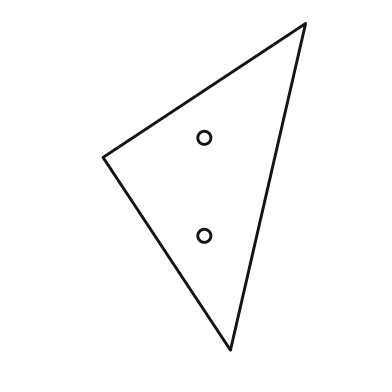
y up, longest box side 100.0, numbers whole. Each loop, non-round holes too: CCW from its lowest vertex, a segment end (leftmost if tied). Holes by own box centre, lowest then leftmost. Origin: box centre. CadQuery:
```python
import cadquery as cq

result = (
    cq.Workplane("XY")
    .moveTo(8.0, -50.0)
    .lineTo(31.0, 50.0)
    .lineTo(-31.0, 9.0)
    .close()
    .moveTo(0.0, -15.0)
    .circle(2.0)
    .moveTo(0.0, 15.0)
    .circle(2.0)
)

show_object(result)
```